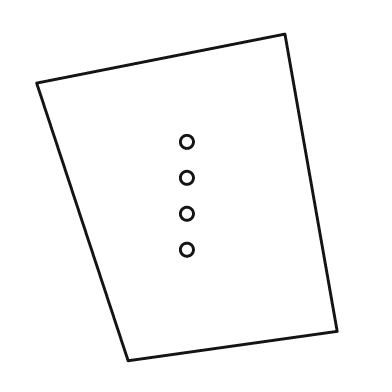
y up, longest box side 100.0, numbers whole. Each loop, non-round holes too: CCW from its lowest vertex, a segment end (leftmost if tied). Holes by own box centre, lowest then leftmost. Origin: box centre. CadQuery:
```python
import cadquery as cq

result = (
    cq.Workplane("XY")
    .moveTo(-18.0, -50.0)
    .lineTo(46.0, -41.0)
    .lineTo(30.0, 50.0)
    .lineTo(-46.0, 35.0)
    .close()
    .moveTo(0.0, -16.0)
    .circle(2.0)
    .moveTo(0.0, -5.0)
    .circle(2.0)
    .moveTo(0.0, 6.0)
    .circle(2.0)
    .moveTo(0.0, 17.0)
    .circle(2.0)
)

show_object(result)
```